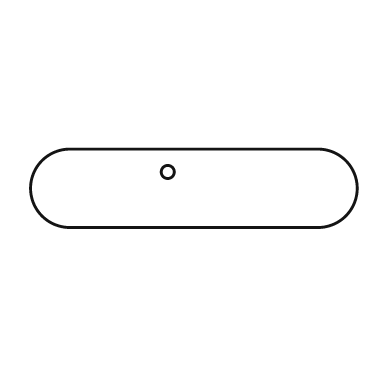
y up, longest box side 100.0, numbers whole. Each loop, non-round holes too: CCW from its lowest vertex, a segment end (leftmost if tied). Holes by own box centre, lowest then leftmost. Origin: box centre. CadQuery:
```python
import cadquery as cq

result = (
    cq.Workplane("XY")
    .moveTo(-38.0, -12.0)
    .lineTo(38.0, -12.0)
    .threePointArc((50.0, 0.0), (38.0, 12.0))
    .lineTo(-38.0, 12.0)
    .threePointArc((-50.0, 0.0), (-38.0, -12.0))
    .close()
    .moveTo(-8.0, 5.0)
    .circle(2.0)
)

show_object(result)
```